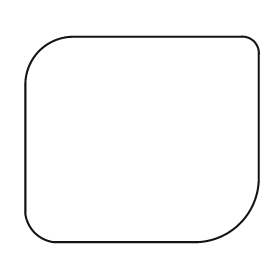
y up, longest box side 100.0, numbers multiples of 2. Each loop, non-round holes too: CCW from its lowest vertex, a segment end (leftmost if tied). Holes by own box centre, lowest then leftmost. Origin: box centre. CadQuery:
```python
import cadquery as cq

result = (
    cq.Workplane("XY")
    .moveTo(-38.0, -44.0)
    .lineTo(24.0, -44.0)
    .threePointArc((42.0, -36.0), (50.0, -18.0))
    .lineTo(50.0, 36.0)
    .threePointArc((48.0, 42.0), (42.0, 44.0))
    .lineTo(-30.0, 44.0)
    .threePointArc((-44.0, 38.0), (-50.0, 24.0))
    .lineTo(-50.0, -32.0)
    .threePointArc((-46.0, -40.0), (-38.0, -44.0))
    .close()
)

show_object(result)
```